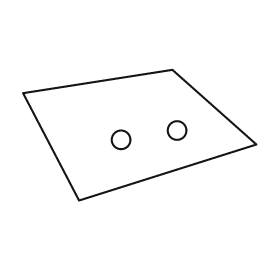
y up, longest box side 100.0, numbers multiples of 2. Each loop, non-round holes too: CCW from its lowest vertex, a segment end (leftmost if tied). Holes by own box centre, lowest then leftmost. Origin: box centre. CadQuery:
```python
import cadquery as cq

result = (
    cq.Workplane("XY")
    .moveTo(-26.0, -28.0)
    .lineTo(50.0, -4.0)
    .lineTo(14.0, 28.0)
    .lineTo(-50.0, 18.0)
    .close()
    .moveTo(-8.0, -2.0)
    .circle(4.0)
    .moveTo(16.0, 2.0)
    .circle(4.0)
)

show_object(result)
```